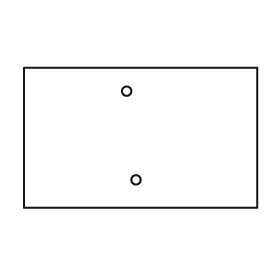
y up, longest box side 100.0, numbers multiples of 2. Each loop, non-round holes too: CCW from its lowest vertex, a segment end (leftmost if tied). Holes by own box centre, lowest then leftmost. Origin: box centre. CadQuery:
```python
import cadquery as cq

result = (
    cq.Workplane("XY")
    .moveTo(-50.0, -30.0)
    .lineTo(50.0, -30.0)
    .lineTo(50.0, 30.0)
    .lineTo(-50.0, 30.0)
    .close()
    .moveTo(-2.0, -18.0)
    .circle(2.0)
    .moveTo(-6.0, 20.0)
    .circle(2.0)
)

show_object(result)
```